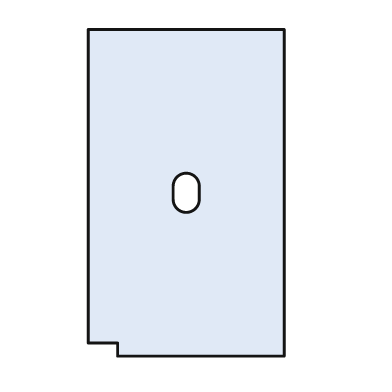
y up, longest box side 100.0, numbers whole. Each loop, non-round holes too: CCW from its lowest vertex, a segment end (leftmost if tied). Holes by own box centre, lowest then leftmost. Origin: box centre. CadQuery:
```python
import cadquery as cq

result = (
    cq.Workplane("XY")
    .moveTo(-21.0, -50.0)
    .lineTo(30.0, -50.0)
    .lineTo(30.0, 50.0)
    .lineTo(-30.0, 50.0)
    .lineTo(-30.0, -46.0)
    .lineTo(-21.0, -46.0)
    .close()
    .moveTo(-4.0, -2.0)
    .threePointArc((0.0, -6.0), (4.0, -2.0))
    .lineTo(4.0, 2.0)
    .threePointArc((0.0, 6.0), (-4.0, 2.0))
    .close()
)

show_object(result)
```